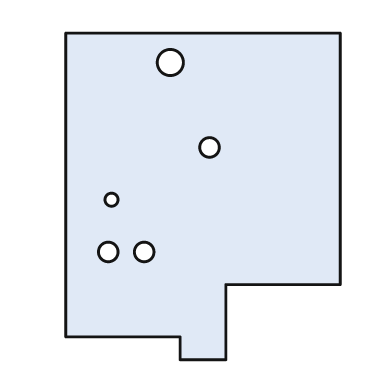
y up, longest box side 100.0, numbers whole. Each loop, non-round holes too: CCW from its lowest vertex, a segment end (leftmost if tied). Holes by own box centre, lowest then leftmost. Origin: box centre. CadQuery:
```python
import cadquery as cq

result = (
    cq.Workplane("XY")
    .moveTo(-7.0, -50.0)
    .lineTo(7.0, -50.0)
    .lineTo(7.0, -27.0)
    .lineTo(42.0, -27.0)
    .lineTo(42.0, 50.0)
    .lineTo(-42.0, 50.0)
    .lineTo(-42.0, -43.0)
    .lineTo(-7.0, -43.0)
    .close()
    .moveTo(-29.0, -17.0)
    .circle(3.0)
    .moveTo(-18.0, -17.0)
    .circle(3.0)
    .moveTo(-28.0, -1.0)
    .circle(2.0)
    .moveTo(2.0, 15.0)
    .circle(3.0)
    .moveTo(-10.0, 41.0)
    .circle(4.0)
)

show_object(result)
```